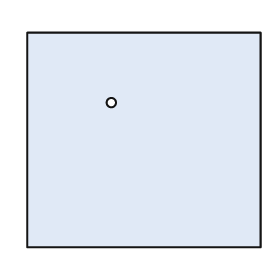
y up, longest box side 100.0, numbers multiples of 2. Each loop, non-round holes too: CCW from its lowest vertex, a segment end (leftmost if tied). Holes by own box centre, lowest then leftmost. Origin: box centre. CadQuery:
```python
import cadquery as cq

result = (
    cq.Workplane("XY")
    .moveTo(-50.0, -46.0)
    .lineTo(50.0, -46.0)
    .lineTo(50.0, 46.0)
    .lineTo(-50.0, 46.0)
    .close()
    .moveTo(-14.0, 16.0)
    .circle(2.0)
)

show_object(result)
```